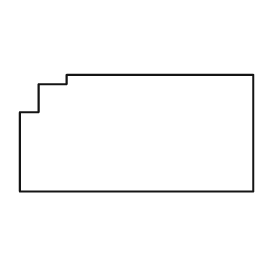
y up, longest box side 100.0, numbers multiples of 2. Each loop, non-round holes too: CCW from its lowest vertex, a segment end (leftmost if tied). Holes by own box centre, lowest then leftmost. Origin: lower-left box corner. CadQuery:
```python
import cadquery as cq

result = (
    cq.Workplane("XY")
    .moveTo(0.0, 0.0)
    .lineTo(100.0, 0.0)
    .lineTo(100.0, 50.0)
    .lineTo(20.0, 50.0)
    .lineTo(20.0, 46.0)
    .lineTo(8.0, 46.0)
    .lineTo(8.0, 34.0)
    .lineTo(0.0, 34.0)
    .close()
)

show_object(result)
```